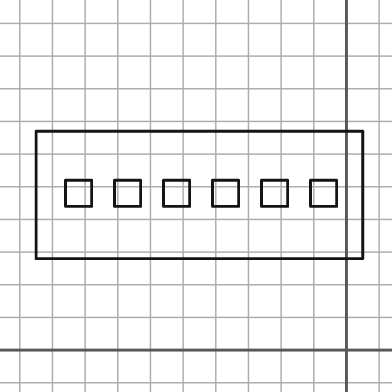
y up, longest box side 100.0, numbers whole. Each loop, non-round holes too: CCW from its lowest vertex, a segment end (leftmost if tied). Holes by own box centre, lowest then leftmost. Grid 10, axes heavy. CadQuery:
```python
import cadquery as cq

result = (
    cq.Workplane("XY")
    .moveTo(-95.0, 28.0)
    .lineTo(5.0, 28.0)
    .lineTo(5.0, 67.0)
    .lineTo(-95.0, 67.0)
    .close()
    .moveTo(-86.0, 44.0)
    .lineTo(-78.0, 44.0)
    .lineTo(-78.0, 52.0)
    .lineTo(-86.0, 52.0)
    .close()
    .moveTo(-71.0, 44.0)
    .lineTo(-63.0, 44.0)
    .lineTo(-63.0, 52.0)
    .lineTo(-71.0, 52.0)
    .close()
    .moveTo(-56.0, 44.0)
    .lineTo(-48.0, 44.0)
    .lineTo(-48.0, 52.0)
    .lineTo(-56.0, 52.0)
    .close()
    .moveTo(-41.0, 44.0)
    .lineTo(-33.0, 44.0)
    .lineTo(-33.0, 52.0)
    .lineTo(-41.0, 52.0)
    .close()
    .moveTo(-26.0, 44.0)
    .lineTo(-18.0, 44.0)
    .lineTo(-18.0, 52.0)
    .lineTo(-26.0, 52.0)
    .close()
    .moveTo(-11.0, 44.0)
    .lineTo(-3.0, 44.0)
    .lineTo(-3.0, 52.0)
    .lineTo(-11.0, 52.0)
    .close()
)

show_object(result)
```